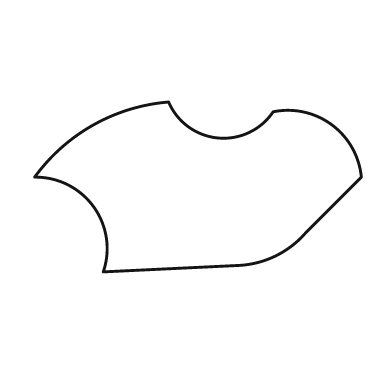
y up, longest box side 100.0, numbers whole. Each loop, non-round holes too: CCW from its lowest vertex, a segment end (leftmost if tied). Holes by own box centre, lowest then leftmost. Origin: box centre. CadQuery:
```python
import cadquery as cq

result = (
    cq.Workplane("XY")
    .moveTo(-29.0, -26.0)
    .lineTo(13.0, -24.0)
    .threePointArc((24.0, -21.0), (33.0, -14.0))
    .lineTo(50.0, 3.0)
    .threePointArc((41.0, 19.0), (23.0, 23.0))
    .threePointArc((6.0, 15.0), (-9.0, 26.0))
    .threePointArc((-32.0, 19.0), (-50.0, 3.0))
    .threePointArc((-32.0, -6.0), (-29.0, -26.0))
    .close()
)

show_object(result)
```